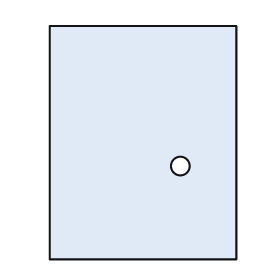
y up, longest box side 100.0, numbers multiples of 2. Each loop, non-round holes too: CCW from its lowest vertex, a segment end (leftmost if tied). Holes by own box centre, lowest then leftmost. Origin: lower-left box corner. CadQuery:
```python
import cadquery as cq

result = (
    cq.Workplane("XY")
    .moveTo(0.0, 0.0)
    .lineTo(80.0, 0.0)
    .lineTo(80.0, 100.0)
    .lineTo(0.0, 100.0)
    .close()
    .moveTo(56.0, 40.0)
    .circle(4.0)
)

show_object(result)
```